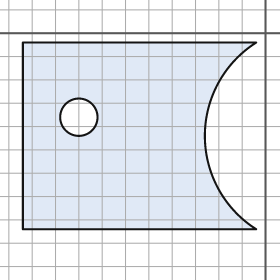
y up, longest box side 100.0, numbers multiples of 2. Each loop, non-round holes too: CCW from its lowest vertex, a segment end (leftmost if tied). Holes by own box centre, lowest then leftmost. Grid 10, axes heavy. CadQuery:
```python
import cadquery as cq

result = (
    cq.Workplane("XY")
    .moveTo(-104.0, -84.0)
    .lineTo(-4.0, -84.0)
    .threePointArc((-26.0, -44.0), (-4.0, -4.0))
    .lineTo(-104.0, -4.0)
    .close()
    .moveTo(-80.0, -36.0)
    .circle(8.0)
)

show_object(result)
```